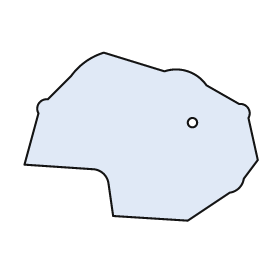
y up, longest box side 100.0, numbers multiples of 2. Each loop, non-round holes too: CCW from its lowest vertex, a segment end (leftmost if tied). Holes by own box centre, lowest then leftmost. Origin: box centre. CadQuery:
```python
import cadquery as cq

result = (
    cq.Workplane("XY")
    .moveTo(20.0, -36.0)
    .lineTo(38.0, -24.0)
    .threePointArc((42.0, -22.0), (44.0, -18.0))
    .lineTo(50.0, -10.0)
    .lineTo(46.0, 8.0)
    .threePointArc((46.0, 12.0), (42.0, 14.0))
    .lineTo(28.0, 22.0)
    .threePointArc((20.0, 28.0), (10.0, 28.0))
    .lineTo(-16.0, 36.0)
    .threePointArc((-24.0, 32.0), (-30.0, 26.0))
    .lineTo(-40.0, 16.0)
    .threePointArc((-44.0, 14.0), (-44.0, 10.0))
    .lineTo(-50.0, -12.0)
    .lineTo(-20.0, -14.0)
    .threePointArc((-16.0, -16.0), (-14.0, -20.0))
    .lineTo(-12.0, -34.0)
    .close()
    .moveTo(22.0, 6.0)
    .circle(2.0)
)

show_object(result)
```